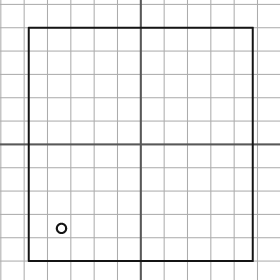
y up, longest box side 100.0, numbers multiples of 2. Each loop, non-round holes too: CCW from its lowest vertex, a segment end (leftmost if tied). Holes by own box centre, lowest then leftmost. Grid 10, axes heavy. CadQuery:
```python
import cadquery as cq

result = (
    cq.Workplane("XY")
    .moveTo(-48.0, -50.0)
    .lineTo(48.0, -50.0)
    .lineTo(48.0, 50.0)
    .lineTo(-48.0, 50.0)
    .close()
    .moveTo(-34.0, -36.0)
    .circle(2.0)
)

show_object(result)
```